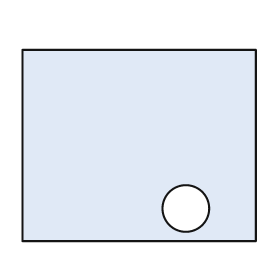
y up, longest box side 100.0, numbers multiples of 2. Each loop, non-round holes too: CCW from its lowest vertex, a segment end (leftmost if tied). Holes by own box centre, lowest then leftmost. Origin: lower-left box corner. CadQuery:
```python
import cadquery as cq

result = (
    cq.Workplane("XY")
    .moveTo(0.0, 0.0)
    .lineTo(100.0, 0.0)
    .lineTo(100.0, 82.0)
    .lineTo(0.0, 82.0)
    .close()
    .moveTo(70.0, 14.0)
    .circle(10.0)
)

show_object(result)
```